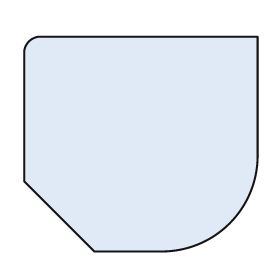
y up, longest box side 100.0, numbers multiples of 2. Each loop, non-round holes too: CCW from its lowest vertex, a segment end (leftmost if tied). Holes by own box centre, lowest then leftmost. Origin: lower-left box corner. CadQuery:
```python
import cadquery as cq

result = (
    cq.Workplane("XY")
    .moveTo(30.0, 0.0)
    .lineTo(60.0, 0.0)
    .threePointArc((88.0, 12.0), (100.0, 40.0))
    .lineTo(100.0, 92.0)
    .lineTo(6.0, 92.0)
    .threePointArc((2.0, 90.0), (0.0, 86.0))
    .lineTo(0.0, 30.0)
    .close()
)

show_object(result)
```